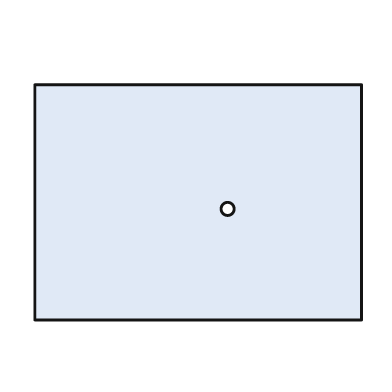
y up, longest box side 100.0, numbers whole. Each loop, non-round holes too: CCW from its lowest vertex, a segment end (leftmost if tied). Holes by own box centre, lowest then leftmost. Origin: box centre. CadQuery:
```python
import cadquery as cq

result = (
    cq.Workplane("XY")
    .moveTo(-50.0, -36.0)
    .lineTo(50.0, -36.0)
    .lineTo(50.0, 36.0)
    .lineTo(-50.0, 36.0)
    .close()
    .moveTo(9.0, -2.0)
    .circle(2.0)
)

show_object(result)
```